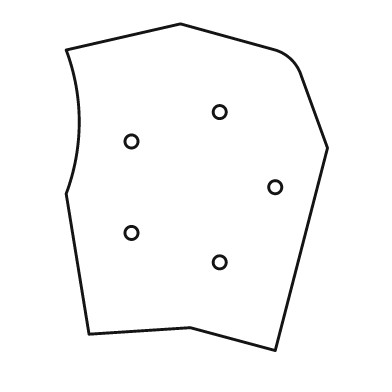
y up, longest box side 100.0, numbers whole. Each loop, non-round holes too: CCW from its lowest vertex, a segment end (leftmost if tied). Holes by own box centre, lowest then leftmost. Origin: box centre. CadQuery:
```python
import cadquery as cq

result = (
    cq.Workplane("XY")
    .moveTo(24.0, -50.0)
    .lineTo(40.0, 12.0)
    .lineTo(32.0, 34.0)
    .threePointArc((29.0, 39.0), (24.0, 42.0))
    .lineTo(-5.0, 50.0)
    .lineTo(-40.0, 42.0)
    .threePointArc((-36.0, 20.0), (-40.0, -2.0))
    .lineTo(-33.0, -45.0)
    .lineTo(-2.0, -43.0)
    .close()
    .moveTo(7.0, -23.0)
    .circle(2.0)
    .moveTo(-20.0, -14.0)
    .circle(2.0)
    .moveTo(24.0, 0.0)
    .circle(2.0)
    .moveTo(-20.0, 14.0)
    .circle(2.0)
    .moveTo(7.0, 23.0)
    .circle(2.0)
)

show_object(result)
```